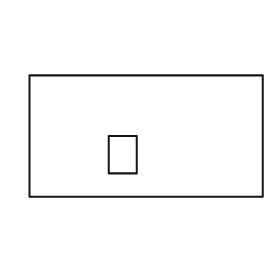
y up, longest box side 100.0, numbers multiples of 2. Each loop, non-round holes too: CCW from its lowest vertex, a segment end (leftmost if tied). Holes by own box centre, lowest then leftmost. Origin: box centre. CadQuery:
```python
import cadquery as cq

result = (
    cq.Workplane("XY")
    .moveTo(-50.0, -26.0)
    .lineTo(50.0, -26.0)
    .lineTo(50.0, 26.0)
    .lineTo(-50.0, 26.0)
    .close()
    .moveTo(-16.0, -16.0)
    .lineTo(-4.0, -16.0)
    .lineTo(-4.0, 0.0)
    .lineTo(-16.0, 0.0)
    .close()
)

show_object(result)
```